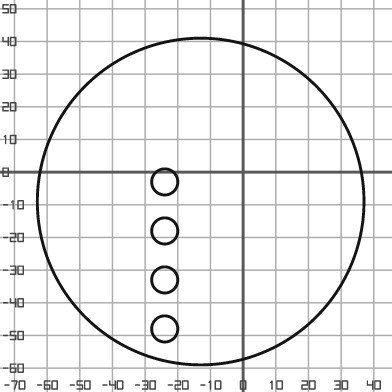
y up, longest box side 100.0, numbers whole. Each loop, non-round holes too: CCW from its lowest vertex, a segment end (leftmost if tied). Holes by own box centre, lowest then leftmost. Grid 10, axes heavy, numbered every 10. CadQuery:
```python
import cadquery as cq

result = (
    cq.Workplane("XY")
    .moveTo(-13.0, -9.0)
    .circle(50.0)
    .moveTo(-24.0, -48.0)
    .circle(4.0)
    .moveTo(-24.0, -33.0)
    .circle(4.0)
    .moveTo(-24.0, -18.0)
    .circle(4.0)
    .moveTo(-24.0, -3.0)
    .circle(4.0)
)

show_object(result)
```